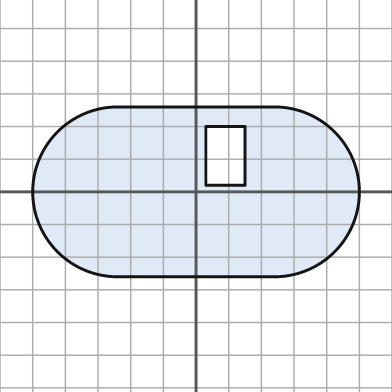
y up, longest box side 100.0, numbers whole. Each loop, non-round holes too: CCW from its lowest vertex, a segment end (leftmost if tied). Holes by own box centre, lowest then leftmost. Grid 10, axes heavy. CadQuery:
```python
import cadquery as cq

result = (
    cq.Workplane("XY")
    .moveTo(-24.0, -26.0)
    .lineTo(24.0, -26.0)
    .threePointArc((50.0, 0.0), (24.0, 26.0))
    .lineTo(-24.0, 26.0)
    .threePointArc((-50.0, 0.0), (-24.0, -26.0))
    .close()
    .moveTo(3.0, 2.0)
    .lineTo(15.0, 2.0)
    .lineTo(15.0, 20.0)
    .lineTo(3.0, 20.0)
    .close()
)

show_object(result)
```